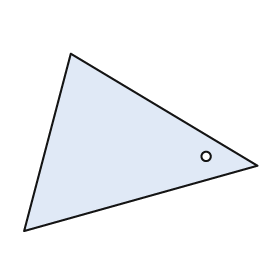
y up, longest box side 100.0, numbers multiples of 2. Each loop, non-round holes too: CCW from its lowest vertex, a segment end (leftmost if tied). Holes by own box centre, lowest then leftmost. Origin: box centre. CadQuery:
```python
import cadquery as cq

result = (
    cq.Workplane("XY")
    .moveTo(-50.0, -38.0)
    .lineTo(50.0, -10.0)
    .lineTo(-30.0, 38.0)
    .close()
    .moveTo(28.0, -6.0)
    .circle(2.0)
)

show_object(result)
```